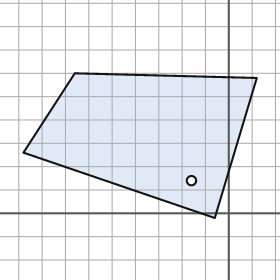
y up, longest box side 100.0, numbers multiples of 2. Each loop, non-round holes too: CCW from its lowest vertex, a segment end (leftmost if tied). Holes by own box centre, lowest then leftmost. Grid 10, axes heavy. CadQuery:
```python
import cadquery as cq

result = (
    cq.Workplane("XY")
    .moveTo(-6.0, -2.0)
    .lineTo(12.0, 58.0)
    .lineTo(-66.0, 60.0)
    .lineTo(-88.0, 26.0)
    .close()
    .moveTo(-16.0, 14.0)
    .circle(2.0)
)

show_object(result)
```